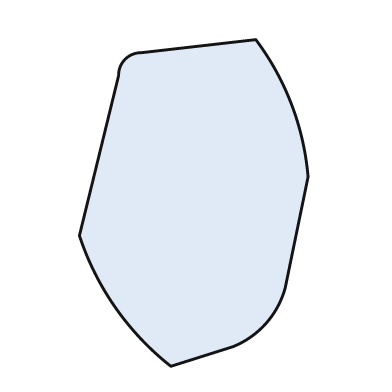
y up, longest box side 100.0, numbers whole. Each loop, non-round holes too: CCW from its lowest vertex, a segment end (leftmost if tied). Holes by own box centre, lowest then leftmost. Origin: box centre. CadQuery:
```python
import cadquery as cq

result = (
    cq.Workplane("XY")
    .moveTo(-7.0, -50.0)
    .lineTo(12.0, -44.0)
    .threePointArc((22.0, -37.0), (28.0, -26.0))
    .lineTo(35.0, 8.0)
    .threePointArc((30.0, 30.0), (19.0, 50.0))
    .lineTo(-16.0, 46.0)
    .threePointArc((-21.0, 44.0), (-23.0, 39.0))
    .lineTo(-35.0, -10.0)
    .threePointArc((-24.0, -32.0), (-7.0, -50.0))
    .close()
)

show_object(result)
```